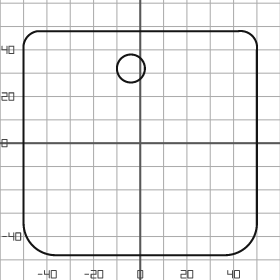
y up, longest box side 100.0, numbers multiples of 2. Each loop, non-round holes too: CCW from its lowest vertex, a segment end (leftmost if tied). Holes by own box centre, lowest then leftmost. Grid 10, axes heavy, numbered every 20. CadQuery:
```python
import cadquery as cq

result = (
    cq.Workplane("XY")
    .moveTo(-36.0, -48.0)
    .lineTo(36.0, -48.0)
    .threePointArc((46.0, -44.0), (50.0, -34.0))
    .lineTo(50.0, 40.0)
    .threePointArc((48.0, 46.0), (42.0, 48.0))
    .lineTo(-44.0, 48.0)
    .threePointArc((-48.0, 46.0), (-50.0, 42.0))
    .lineTo(-50.0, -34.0)
    .threePointArc((-46.0, -44.0), (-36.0, -48.0))
    .close()
    .moveTo(-4.0, 32.0)
    .circle(6.0)
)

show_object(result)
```